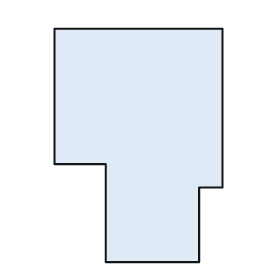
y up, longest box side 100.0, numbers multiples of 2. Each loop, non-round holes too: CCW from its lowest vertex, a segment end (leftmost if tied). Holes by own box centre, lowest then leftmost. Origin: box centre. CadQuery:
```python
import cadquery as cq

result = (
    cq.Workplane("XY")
    .moveTo(-14.0, -50.0)
    .lineTo(26.0, -50.0)
    .lineTo(26.0, -18.0)
    .lineTo(36.0, -18.0)
    .lineTo(36.0, 50.0)
    .lineTo(-36.0, 50.0)
    .lineTo(-36.0, -8.0)
    .lineTo(-14.0, -8.0)
    .close()
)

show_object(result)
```